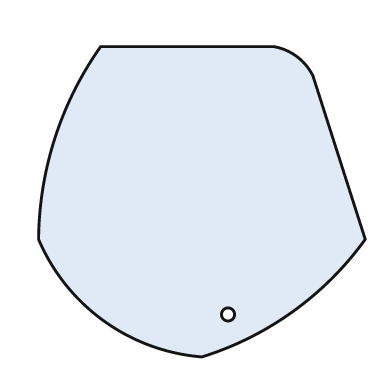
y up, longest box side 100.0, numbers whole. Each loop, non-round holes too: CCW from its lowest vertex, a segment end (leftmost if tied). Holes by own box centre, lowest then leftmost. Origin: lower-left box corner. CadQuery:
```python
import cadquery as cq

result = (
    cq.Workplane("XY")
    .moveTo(50.0, 0.0)
    .threePointArc((78.0, 14.0), (100.0, 36.0))
    .lineTo(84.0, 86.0)
    .threePointArc((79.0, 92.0), (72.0, 95.0))
    .lineTo(19.0, 95.0)
    .threePointArc((5.0, 67.0), (0.0, 36.0))
    .threePointArc((20.0, 11.0), (50.0, 0.0))
    .close()
    .moveTo(58.0, 13.0)
    .circle(2.0)
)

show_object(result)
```